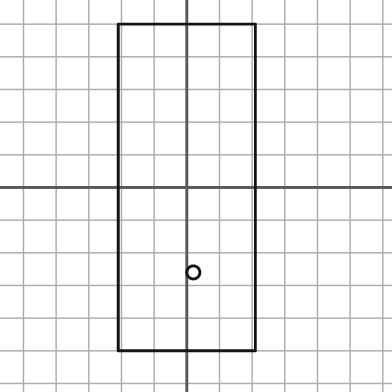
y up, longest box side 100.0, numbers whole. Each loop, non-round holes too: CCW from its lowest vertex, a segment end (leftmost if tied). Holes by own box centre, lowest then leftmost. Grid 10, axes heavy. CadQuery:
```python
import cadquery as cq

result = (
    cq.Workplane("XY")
    .moveTo(-21.0, -50.0)
    .lineTo(21.0, -50.0)
    .lineTo(21.0, 50.0)
    .lineTo(-21.0, 50.0)
    .close()
    .moveTo(2.0, -26.0)
    .circle(2.0)
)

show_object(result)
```